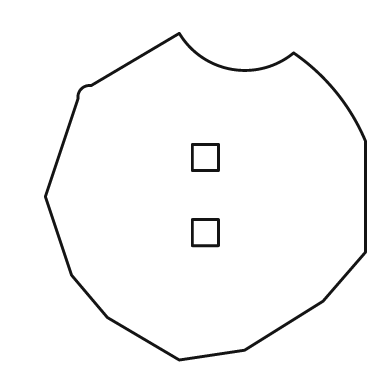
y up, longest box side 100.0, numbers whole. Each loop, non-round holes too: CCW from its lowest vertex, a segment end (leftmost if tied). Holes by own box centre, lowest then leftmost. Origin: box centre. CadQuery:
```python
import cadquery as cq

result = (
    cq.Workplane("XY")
    .moveTo(-8.0, -50.0)
    .lineTo(12.0, -47.0)
    .lineTo(36.0, -32.0)
    .lineTo(49.0, -17.0)
    .lineTo(49.0, 17.0)
    .threePointArc((40.0, 32.0), (27.0, 44.0))
    .threePointArc((8.0, 39.0), (-8.0, 50.0))
    .lineTo(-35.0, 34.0)
    .threePointArc((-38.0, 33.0), (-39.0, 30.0))
    .lineTo(-49.0, 0.0)
    .lineTo(-41.0, -24.0)
    .lineTo(-30.0, -37.0)
    .close()
    .moveTo(-4.0, -15.0)
    .lineTo(4.0, -15.0)
    .lineTo(4.0, -7.0)
    .lineTo(-4.0, -7.0)
    .close()
    .moveTo(-4.0, 8.0)
    .lineTo(4.0, 8.0)
    .lineTo(4.0, 16.0)
    .lineTo(-4.0, 16.0)
    .close()
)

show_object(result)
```